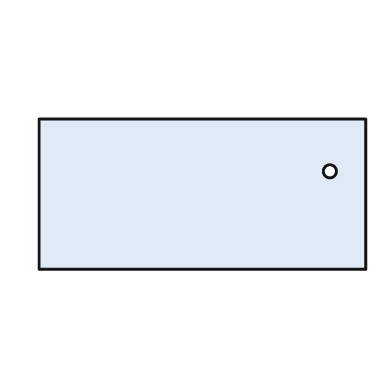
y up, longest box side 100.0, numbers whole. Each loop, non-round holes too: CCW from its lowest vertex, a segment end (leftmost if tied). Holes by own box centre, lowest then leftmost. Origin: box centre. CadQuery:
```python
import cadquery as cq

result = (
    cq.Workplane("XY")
    .moveTo(-50.0, -23.0)
    .lineTo(50.0, -23.0)
    .lineTo(50.0, 23.0)
    .lineTo(-50.0, 23.0)
    .close()
    .moveTo(39.0, 7.0)
    .circle(2.0)
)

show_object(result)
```